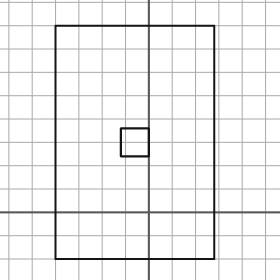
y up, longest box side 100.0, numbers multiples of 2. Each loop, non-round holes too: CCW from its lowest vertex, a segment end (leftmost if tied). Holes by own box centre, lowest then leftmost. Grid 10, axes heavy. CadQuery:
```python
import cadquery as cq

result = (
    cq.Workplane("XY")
    .moveTo(-40.0, -20.0)
    .lineTo(28.0, -20.0)
    .lineTo(28.0, 80.0)
    .lineTo(-40.0, 80.0)
    .close()
    .moveTo(-12.0, 24.0)
    .lineTo(0.0, 24.0)
    .lineTo(0.0, 36.0)
    .lineTo(-12.0, 36.0)
    .close()
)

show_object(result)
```